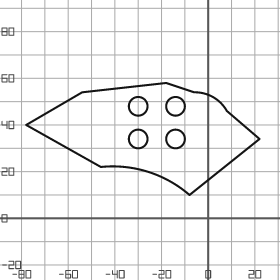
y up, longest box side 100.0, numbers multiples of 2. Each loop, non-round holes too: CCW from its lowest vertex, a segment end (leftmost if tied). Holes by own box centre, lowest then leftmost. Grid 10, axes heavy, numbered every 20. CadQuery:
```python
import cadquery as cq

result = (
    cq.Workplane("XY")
    .moveTo(-8.0, 10.0)
    .lineTo(22.0, 34.0)
    .lineTo(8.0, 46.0)
    .threePointArc((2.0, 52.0), (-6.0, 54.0))
    .lineTo(-18.0, 58.0)
    .lineTo(-54.0, 54.0)
    .lineTo(-78.0, 40.0)
    .lineTo(-46.0, 22.0)
    .threePointArc((-26.0, 20.0), (-8.0, 10.0))
    .close()
    .moveTo(-30.0, 34.0)
    .circle(4.0)
    .moveTo(-14.0, 34.0)
    .circle(4.0)
    .moveTo(-30.0, 48.0)
    .circle(4.0)
    .moveTo(-14.0, 48.0)
    .circle(4.0)
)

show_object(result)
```